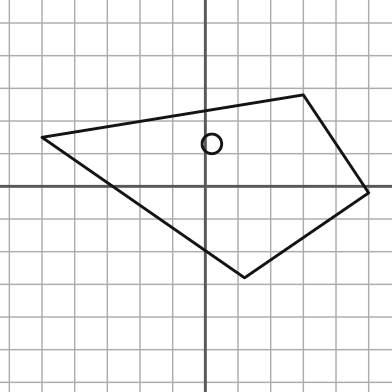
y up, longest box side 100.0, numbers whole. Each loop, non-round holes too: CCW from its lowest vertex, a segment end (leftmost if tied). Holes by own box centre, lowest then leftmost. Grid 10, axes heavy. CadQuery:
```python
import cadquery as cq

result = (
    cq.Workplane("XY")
    .moveTo(12.0, -28.0)
    .lineTo(50.0, -2.0)
    .lineTo(30.0, 28.0)
    .lineTo(-50.0, 15.0)
    .close()
    .moveTo(2.0, 13.0)
    .circle(3.0)
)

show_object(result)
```